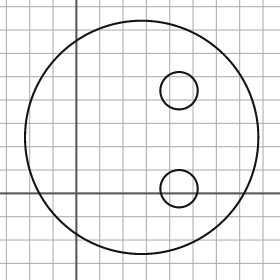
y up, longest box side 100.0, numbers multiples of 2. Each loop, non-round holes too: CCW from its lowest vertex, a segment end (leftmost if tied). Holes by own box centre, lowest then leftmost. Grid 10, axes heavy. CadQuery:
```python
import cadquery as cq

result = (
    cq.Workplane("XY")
    .moveTo(28.0, 24.0)
    .circle(50.0)
    .moveTo(44.0, 2.0)
    .circle(8.0)
    .moveTo(44.0, 44.0)
    .circle(8.0)
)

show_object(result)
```